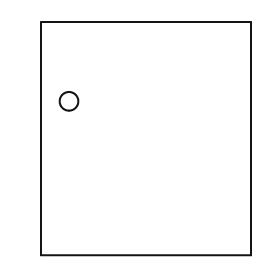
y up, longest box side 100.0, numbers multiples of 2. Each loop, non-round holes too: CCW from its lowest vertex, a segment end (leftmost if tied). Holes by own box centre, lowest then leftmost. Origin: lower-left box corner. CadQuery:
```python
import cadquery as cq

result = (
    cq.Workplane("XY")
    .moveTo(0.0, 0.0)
    .lineTo(90.0, 0.0)
    .lineTo(90.0, 100.0)
    .lineTo(0.0, 100.0)
    .close()
    .moveTo(12.0, 66.0)
    .circle(4.0)
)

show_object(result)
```